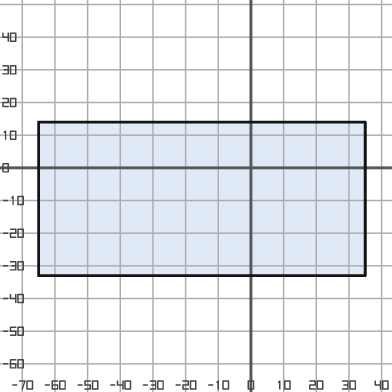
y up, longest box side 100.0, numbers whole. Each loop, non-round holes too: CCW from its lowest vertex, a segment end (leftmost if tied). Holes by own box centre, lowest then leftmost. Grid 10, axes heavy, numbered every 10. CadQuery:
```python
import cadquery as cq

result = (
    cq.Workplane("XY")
    .moveTo(-65.0, -33.0)
    .lineTo(35.0, -33.0)
    .lineTo(35.0, 14.0)
    .lineTo(-65.0, 14.0)
    .close()
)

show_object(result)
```